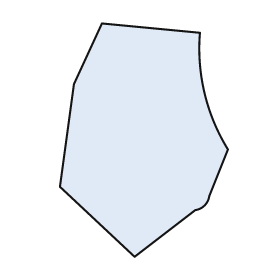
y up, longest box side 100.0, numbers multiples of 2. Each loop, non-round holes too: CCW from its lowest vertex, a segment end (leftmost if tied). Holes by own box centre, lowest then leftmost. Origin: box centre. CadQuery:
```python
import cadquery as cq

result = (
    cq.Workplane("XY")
    .moveTo(-4.0, -50.0)
    .lineTo(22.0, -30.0)
    .threePointArc((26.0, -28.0), (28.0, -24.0))
    .lineTo(36.0, -4.0)
    .threePointArc((26.0, 20.0), (24.0, 46.0))
    .lineTo(-18.0, 50.0)
    .lineTo(-30.0, 24.0)
    .lineTo(-36.0, -20.0)
    .close()
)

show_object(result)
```